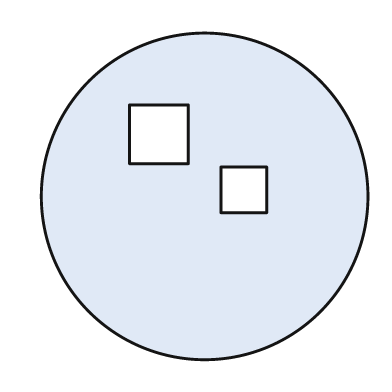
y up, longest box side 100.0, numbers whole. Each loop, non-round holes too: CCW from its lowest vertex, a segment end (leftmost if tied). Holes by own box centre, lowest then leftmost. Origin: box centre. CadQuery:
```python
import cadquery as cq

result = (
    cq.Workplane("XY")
    .moveTo(0.0, 0.0)
    .circle(50.0)
    .moveTo(5.0, -5.0)
    .lineTo(19.0, -5.0)
    .lineTo(19.0, 9.0)
    .lineTo(5.0, 9.0)
    .close()
    .moveTo(-23.0, 10.0)
    .lineTo(-5.0, 10.0)
    .lineTo(-5.0, 28.0)
    .lineTo(-23.0, 28.0)
    .close()
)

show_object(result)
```